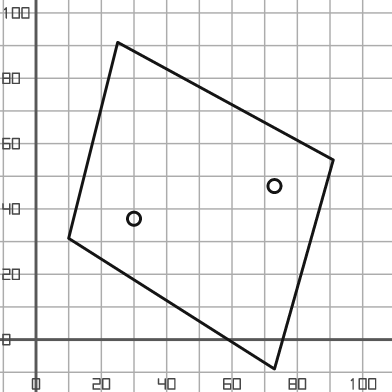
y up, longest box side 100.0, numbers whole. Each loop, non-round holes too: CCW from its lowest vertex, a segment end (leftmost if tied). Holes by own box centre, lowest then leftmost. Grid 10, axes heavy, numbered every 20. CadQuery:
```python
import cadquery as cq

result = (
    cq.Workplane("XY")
    .moveTo(73.0, -9.0)
    .lineTo(91.0, 55.0)
    .lineTo(25.0, 91.0)
    .lineTo(10.0, 31.0)
    .close()
    .moveTo(30.0, 37.0)
    .circle(2.0)
    .moveTo(73.0, 47.0)
    .circle(2.0)
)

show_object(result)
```